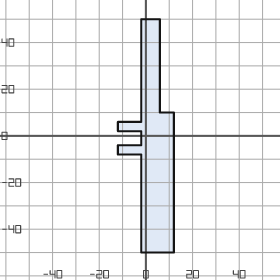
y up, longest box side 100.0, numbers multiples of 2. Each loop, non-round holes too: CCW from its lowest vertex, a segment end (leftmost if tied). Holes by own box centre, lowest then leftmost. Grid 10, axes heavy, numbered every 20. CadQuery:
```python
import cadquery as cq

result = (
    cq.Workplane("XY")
    .moveTo(-2.0, -50.0)
    .lineTo(12.0, -50.0)
    .lineTo(12.0, 10.0)
    .lineTo(6.0, 10.0)
    .lineTo(6.0, 50.0)
    .lineTo(-2.0, 50.0)
    .lineTo(-2.0, 6.0)
    .lineTo(-12.0, 6.0)
    .lineTo(-12.0, 2.0)
    .lineTo(-2.0, 2.0)
    .lineTo(-2.0, -4.0)
    .lineTo(-12.0, -4.0)
    .lineTo(-12.0, -8.0)
    .lineTo(-2.0, -8.0)
    .close()
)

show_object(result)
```